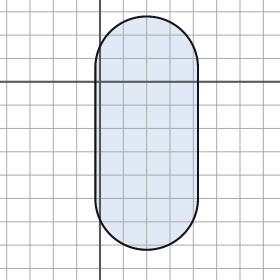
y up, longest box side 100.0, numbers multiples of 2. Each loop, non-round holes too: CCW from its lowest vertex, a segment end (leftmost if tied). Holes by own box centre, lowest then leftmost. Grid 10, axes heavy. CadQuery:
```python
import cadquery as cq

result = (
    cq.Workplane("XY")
    .moveTo(-2.0, -50.0)
    .threePointArc((20.0, -72.0), (42.0, -50.0))
    .lineTo(42.0, 6.0)
    .threePointArc((20.0, 28.0), (-2.0, 6.0))
    .close()
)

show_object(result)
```